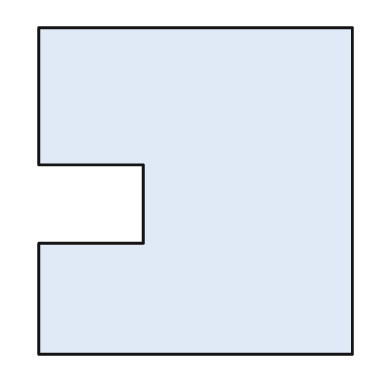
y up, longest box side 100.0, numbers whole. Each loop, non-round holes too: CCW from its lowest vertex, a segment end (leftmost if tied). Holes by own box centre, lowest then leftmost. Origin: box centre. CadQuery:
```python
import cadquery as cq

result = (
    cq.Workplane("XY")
    .moveTo(-48.0, -50.0)
    .lineTo(48.0, -50.0)
    .lineTo(48.0, 50.0)
    .lineTo(-48.0, 50.0)
    .lineTo(-48.0, 8.0)
    .lineTo(-16.0, 8.0)
    .lineTo(-16.0, -16.0)
    .lineTo(-48.0, -16.0)
    .close()
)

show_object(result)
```